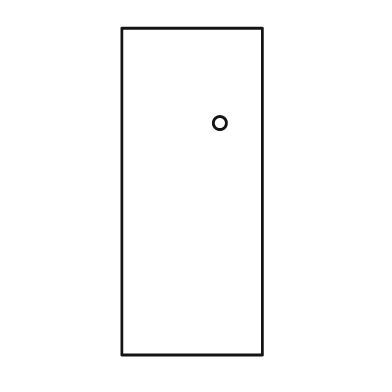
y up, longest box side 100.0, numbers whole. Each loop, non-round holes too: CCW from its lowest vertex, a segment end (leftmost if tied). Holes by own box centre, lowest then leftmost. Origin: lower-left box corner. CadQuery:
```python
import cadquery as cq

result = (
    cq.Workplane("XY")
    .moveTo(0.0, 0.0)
    .lineTo(43.0, 0.0)
    .lineTo(43.0, 100.0)
    .lineTo(0.0, 100.0)
    .close()
    .moveTo(30.0, 71.0)
    .circle(2.0)
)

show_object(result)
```